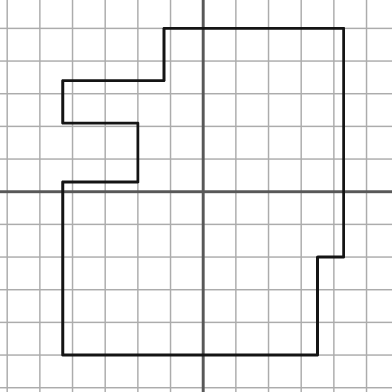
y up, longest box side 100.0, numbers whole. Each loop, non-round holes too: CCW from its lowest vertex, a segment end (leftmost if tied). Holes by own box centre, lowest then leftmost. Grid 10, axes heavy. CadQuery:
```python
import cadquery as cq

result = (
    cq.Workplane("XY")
    .moveTo(-43.0, -50.0)
    .lineTo(35.0, -50.0)
    .lineTo(35.0, -20.0)
    .lineTo(43.0, -20.0)
    .lineTo(43.0, 50.0)
    .lineTo(-12.0, 50.0)
    .lineTo(-12.0, 34.0)
    .lineTo(-43.0, 34.0)
    .lineTo(-43.0, 21.0)
    .lineTo(-20.0, 21.0)
    .lineTo(-20.0, 3.0)
    .lineTo(-43.0, 3.0)
    .close()
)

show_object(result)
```